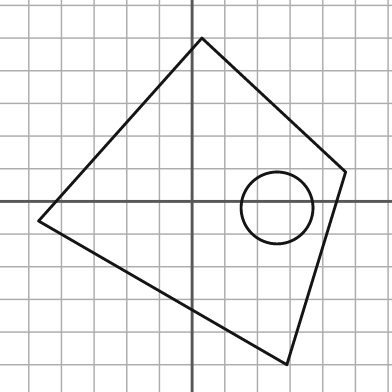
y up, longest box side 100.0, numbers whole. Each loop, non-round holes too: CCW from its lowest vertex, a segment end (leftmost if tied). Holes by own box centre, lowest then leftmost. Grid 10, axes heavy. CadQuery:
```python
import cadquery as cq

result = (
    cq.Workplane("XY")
    .moveTo(29.0, -50.0)
    .lineTo(47.0, 9.0)
    .lineTo(3.0, 50.0)
    .lineTo(-47.0, -6.0)
    .close()
    .moveTo(26.0, -2.0)
    .circle(11.0)
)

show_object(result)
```